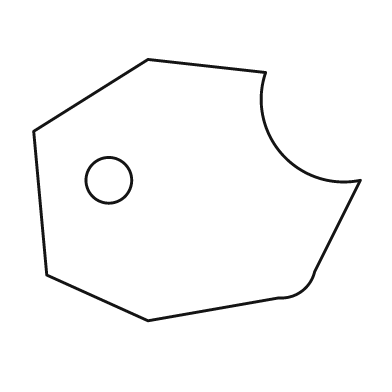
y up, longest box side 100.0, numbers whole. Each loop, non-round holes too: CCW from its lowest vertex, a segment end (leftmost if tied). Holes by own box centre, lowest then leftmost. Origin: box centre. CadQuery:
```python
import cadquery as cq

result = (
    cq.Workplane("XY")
    .moveTo(-15.0, -40.0)
    .lineTo(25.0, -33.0)
    .threePointArc((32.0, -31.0), (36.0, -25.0))
    .lineTo(50.0, 3.0)
    .threePointArc((26.0, 11.0), (21.0, 36.0))
    .lineTo(-15.0, 40.0)
    .lineTo(-50.0, 18.0)
    .lineTo(-46.0, -26.0)
    .close()
    .moveTo(-27.0, 3.0)
    .circle(7.0)
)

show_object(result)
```